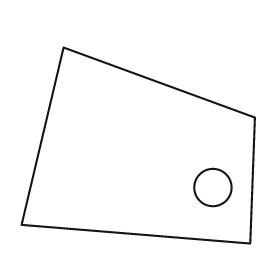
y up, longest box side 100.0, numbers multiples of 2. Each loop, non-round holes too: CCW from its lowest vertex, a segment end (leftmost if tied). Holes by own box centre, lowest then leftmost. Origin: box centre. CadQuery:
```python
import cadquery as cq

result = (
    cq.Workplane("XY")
    .moveTo(48.0, -42.0)
    .lineTo(50.0, 12.0)
    .lineTo(-32.0, 42.0)
    .lineTo(-50.0, -34.0)
    .close()
    .moveTo(32.0, -18.0)
    .circle(8.0)
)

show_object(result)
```